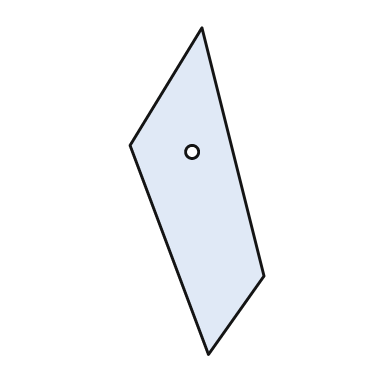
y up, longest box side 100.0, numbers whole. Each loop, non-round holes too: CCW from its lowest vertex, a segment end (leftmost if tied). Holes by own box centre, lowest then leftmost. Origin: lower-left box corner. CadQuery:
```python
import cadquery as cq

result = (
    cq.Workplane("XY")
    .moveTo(24.0, 0.0)
    .lineTo(41.0, 24.0)
    .lineTo(22.0, 100.0)
    .lineTo(0.0, 64.0)
    .close()
    .moveTo(19.0, 62.0)
    .circle(2.0)
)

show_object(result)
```